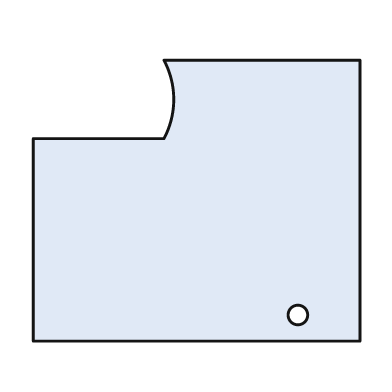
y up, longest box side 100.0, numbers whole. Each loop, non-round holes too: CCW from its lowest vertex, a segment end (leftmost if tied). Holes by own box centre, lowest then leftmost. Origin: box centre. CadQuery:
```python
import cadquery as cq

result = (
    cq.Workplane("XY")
    .moveTo(-50.0, -43.0)
    .lineTo(50.0, -43.0)
    .lineTo(50.0, 43.0)
    .lineTo(-10.0, 43.0)
    .threePointArc((-7.0, 31.0), (-10.0, 19.0))
    .lineTo(-50.0, 19.0)
    .close()
    .moveTo(31.0, -35.0)
    .circle(3.0)
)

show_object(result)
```